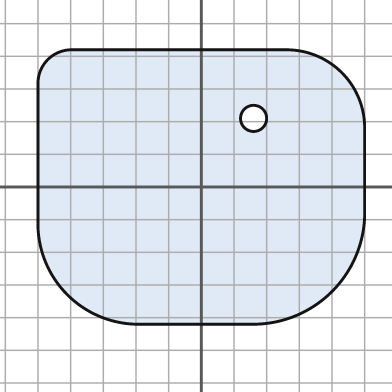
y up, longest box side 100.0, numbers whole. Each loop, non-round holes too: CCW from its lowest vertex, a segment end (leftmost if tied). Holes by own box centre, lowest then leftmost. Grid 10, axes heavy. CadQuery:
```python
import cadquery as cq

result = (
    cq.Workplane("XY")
    .moveTo(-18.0, -42.0)
    .lineTo(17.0, -42.0)
    .threePointArc((40.0, -32.0), (50.0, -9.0))
    .lineTo(50.0, 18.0)
    .threePointArc((43.0, 35.0), (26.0, 42.0))
    .lineTo(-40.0, 42.0)
    .threePointArc((-47.0, 39.0), (-50.0, 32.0))
    .lineTo(-50.0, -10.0)
    .threePointArc((-41.0, -33.0), (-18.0, -42.0))
    .close()
    .moveTo(16.0, 21.0)
    .circle(4.0)
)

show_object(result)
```